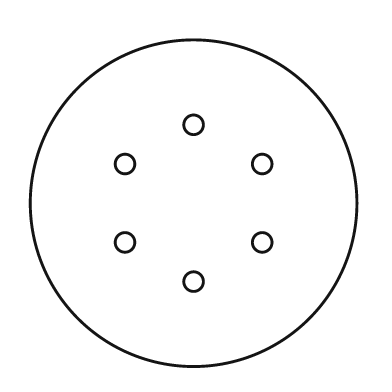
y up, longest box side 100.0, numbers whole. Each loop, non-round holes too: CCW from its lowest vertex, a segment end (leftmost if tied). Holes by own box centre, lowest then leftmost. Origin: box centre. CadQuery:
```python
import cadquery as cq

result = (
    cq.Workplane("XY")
    .moveTo(0.0, 0.0)
    .circle(50.0)
    .moveTo(0.0, -24.0)
    .circle(3.0)
    .moveTo(-21.0, -12.0)
    .circle(3.0)
    .moveTo(21.0, -12.0)
    .circle(3.0)
    .moveTo(-21.0, 12.0)
    .circle(3.0)
    .moveTo(21.0, 12.0)
    .circle(3.0)
    .moveTo(0.0, 24.0)
    .circle(3.0)
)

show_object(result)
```